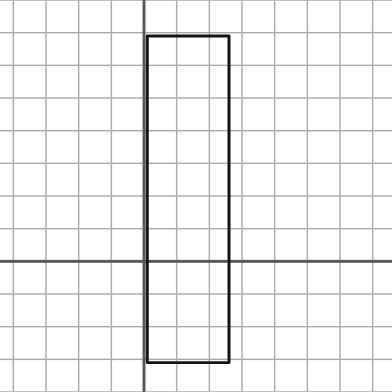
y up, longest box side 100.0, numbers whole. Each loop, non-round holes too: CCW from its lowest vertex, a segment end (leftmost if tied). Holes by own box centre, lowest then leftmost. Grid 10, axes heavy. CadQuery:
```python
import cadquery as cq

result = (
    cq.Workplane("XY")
    .moveTo(1.0, -31.0)
    .lineTo(26.0, -31.0)
    .lineTo(26.0, 69.0)
    .lineTo(1.0, 69.0)
    .close()
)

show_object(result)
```